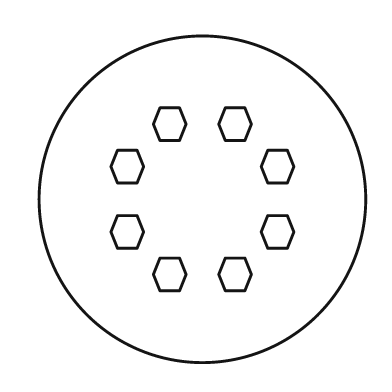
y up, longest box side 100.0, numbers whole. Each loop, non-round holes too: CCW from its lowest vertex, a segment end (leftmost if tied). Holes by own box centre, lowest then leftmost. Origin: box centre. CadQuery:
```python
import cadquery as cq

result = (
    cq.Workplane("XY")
    .moveTo(0.0, 0.0)
    .circle(50.0)
    .moveTo(-13.0, -28.0)
    .lineTo(-7.0, -28.0)
    .lineTo(-5.0, -23.0)
    .lineTo(-7.0, -18.0)
    .lineTo(-13.0, -18.0)
    .lineTo(-15.0, -23.0)
    .close()
    .moveTo(7.0, -28.0)
    .lineTo(13.0, -28.0)
    .lineTo(15.0, -23.0)
    .lineTo(13.0, -18.0)
    .lineTo(7.0, -18.0)
    .lineTo(5.0, -23.0)
    .close()
    .moveTo(-26.0, -15.0)
    .lineTo(-20.0, -15.0)
    .lineTo(-18.0, -10.0)
    .lineTo(-20.0, -5.0)
    .lineTo(-26.0, -5.0)
    .lineTo(-28.0, -10.0)
    .close()
    .moveTo(20.0, -15.0)
    .lineTo(26.0, -15.0)
    .lineTo(28.0, -10.0)
    .lineTo(26.0, -5.0)
    .lineTo(20.0, -5.0)
    .lineTo(18.0, -10.0)
    .close()
    .moveTo(-26.0, 5.0)
    .lineTo(-20.0, 5.0)
    .lineTo(-18.0, 10.0)
    .lineTo(-20.0, 15.0)
    .lineTo(-26.0, 15.0)
    .lineTo(-28.0, 10.0)
    .close()
    .moveTo(20.0, 5.0)
    .lineTo(26.0, 5.0)
    .lineTo(28.0, 10.0)
    .lineTo(26.0, 15.0)
    .lineTo(20.0, 15.0)
    .lineTo(18.0, 10.0)
    .close()
    .moveTo(-13.0, 18.0)
    .lineTo(-7.0, 18.0)
    .lineTo(-5.0, 23.0)
    .lineTo(-7.0, 28.0)
    .lineTo(-13.0, 28.0)
    .lineTo(-15.0, 23.0)
    .close()
    .moveTo(7.0, 18.0)
    .lineTo(13.0, 18.0)
    .lineTo(15.0, 23.0)
    .lineTo(13.0, 28.0)
    .lineTo(7.0, 28.0)
    .lineTo(5.0, 23.0)
    .close()
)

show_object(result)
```